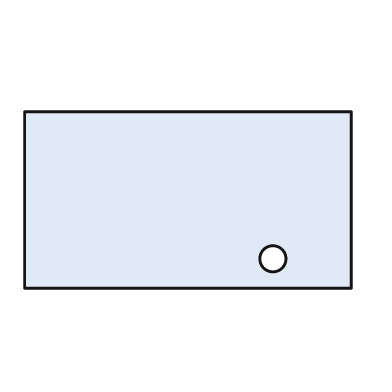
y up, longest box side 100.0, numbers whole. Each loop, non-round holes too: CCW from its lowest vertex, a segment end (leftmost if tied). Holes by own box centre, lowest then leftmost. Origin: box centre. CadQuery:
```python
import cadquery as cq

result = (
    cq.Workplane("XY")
    .moveTo(-50.0, -27.0)
    .lineTo(50.0, -27.0)
    .lineTo(50.0, 27.0)
    .lineTo(-50.0, 27.0)
    .close()
    .moveTo(26.0, -18.0)
    .circle(4.0)
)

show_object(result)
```